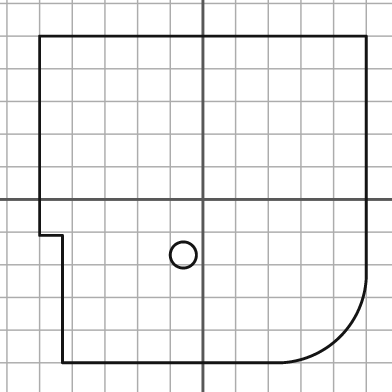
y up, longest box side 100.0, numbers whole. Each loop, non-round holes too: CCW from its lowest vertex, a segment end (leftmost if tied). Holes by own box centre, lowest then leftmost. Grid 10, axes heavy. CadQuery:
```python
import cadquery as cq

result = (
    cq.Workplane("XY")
    .moveTo(-43.0, -50.0)
    .lineTo(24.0, -50.0)
    .threePointArc((42.0, -42.0), (50.0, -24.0))
    .lineTo(50.0, 50.0)
    .lineTo(-50.0, 50.0)
    .lineTo(-50.0, -11.0)
    .lineTo(-43.0, -11.0)
    .close()
    .moveTo(-6.0, -17.0)
    .circle(4.0)
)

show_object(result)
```